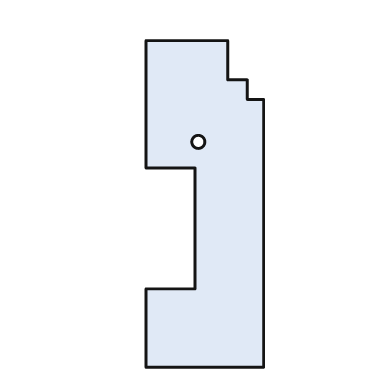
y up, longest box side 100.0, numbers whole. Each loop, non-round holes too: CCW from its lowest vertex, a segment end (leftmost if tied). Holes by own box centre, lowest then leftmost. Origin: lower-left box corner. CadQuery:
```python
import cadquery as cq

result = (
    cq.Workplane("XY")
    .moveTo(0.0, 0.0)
    .lineTo(36.0, 0.0)
    .lineTo(36.0, 82.0)
    .lineTo(31.0, 82.0)
    .lineTo(31.0, 88.0)
    .lineTo(25.0, 88.0)
    .lineTo(25.0, 100.0)
    .lineTo(0.0, 100.0)
    .lineTo(0.0, 61.0)
    .lineTo(15.0, 61.0)
    .lineTo(15.0, 24.0)
    .lineTo(0.0, 24.0)
    .close()
    .moveTo(16.0, 69.0)
    .circle(2.0)
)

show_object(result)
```